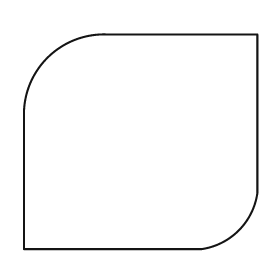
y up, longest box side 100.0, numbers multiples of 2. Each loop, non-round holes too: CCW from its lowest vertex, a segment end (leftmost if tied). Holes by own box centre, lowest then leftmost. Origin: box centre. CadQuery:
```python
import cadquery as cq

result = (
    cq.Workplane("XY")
    .moveTo(-50.0, -46.0)
    .lineTo(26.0, -46.0)
    .threePointArc((42.0, -38.0), (50.0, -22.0))
    .lineTo(50.0, 46.0)
    .lineTo(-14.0, 46.0)
    .threePointArc((-40.0, 36.0), (-50.0, 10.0))
    .close()
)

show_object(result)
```